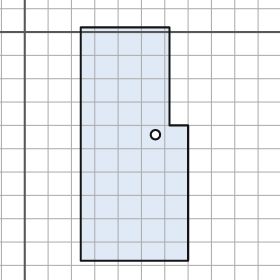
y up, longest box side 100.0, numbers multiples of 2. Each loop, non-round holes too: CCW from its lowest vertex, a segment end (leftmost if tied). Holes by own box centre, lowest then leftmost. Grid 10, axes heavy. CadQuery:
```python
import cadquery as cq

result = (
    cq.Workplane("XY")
    .moveTo(24.0, -98.0)
    .lineTo(70.0, -98.0)
    .lineTo(70.0, -40.0)
    .lineTo(62.0, -40.0)
    .lineTo(62.0, 2.0)
    .lineTo(24.0, 2.0)
    .close()
    .moveTo(56.0, -44.0)
    .circle(2.0)
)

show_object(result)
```